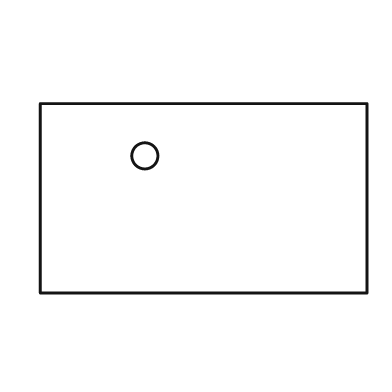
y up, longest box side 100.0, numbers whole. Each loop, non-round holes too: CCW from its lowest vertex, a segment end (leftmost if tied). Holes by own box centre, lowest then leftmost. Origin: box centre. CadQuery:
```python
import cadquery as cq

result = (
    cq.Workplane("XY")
    .moveTo(-50.0, -29.0)
    .lineTo(50.0, -29.0)
    .lineTo(50.0, 29.0)
    .lineTo(-50.0, 29.0)
    .close()
    .moveTo(-18.0, 13.0)
    .circle(4.0)
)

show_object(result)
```